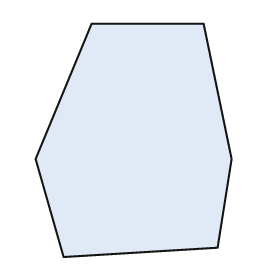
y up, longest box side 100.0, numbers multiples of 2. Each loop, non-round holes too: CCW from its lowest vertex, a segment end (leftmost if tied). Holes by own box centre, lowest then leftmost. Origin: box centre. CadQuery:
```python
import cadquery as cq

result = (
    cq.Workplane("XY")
    .moveTo(-30.0, -50.0)
    .lineTo(36.0, -46.0)
    .lineTo(42.0, -8.0)
    .lineTo(30.0, 50.0)
    .lineTo(-18.0, 50.0)
    .lineTo(-42.0, -8.0)
    .close()
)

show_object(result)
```